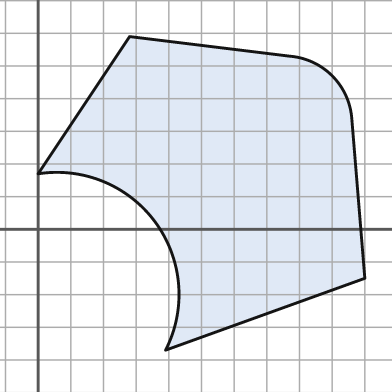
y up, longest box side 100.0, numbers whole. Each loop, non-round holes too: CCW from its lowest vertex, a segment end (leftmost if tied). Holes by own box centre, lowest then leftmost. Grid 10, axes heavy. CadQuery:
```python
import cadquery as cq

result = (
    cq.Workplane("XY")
    .moveTo(39.0, -37.0)
    .lineTo(100.0, -15.0)
    .lineTo(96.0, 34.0)
    .threePointArc((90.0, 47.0), (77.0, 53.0))
    .lineTo(28.0, 59.0)
    .lineTo(0.0, 17.0)
    .threePointArc((36.0, 2.0), (39.0, -37.0))
    .close()
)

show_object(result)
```